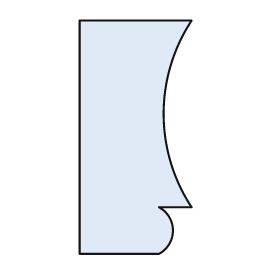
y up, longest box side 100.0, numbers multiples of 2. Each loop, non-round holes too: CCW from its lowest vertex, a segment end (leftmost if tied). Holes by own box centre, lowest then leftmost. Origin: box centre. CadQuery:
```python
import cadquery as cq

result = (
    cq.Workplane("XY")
    .moveTo(-24.0, -50.0)
    .lineTo(10.0, -50.0)
    .threePointArc((16.0, -40.0), (10.0, -30.0))
    .lineTo(24.0, -30.0)
    .threePointArc((12.0, 10.0), (24.0, 50.0))
    .lineTo(-24.0, 50.0)
    .close()
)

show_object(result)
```